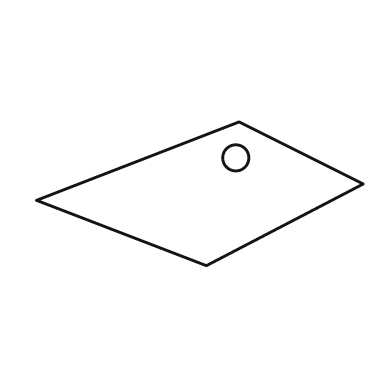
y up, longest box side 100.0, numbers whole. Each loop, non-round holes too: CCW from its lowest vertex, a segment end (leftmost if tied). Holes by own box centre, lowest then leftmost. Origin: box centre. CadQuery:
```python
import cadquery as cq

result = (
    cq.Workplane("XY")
    .moveTo(2.0, -22.0)
    .lineTo(50.0, 3.0)
    .lineTo(12.0, 22.0)
    .lineTo(-50.0, -2.0)
    .close()
    .moveTo(11.0, 11.0)
    .circle(4.0)
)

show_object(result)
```